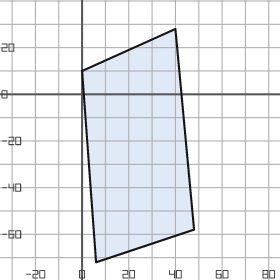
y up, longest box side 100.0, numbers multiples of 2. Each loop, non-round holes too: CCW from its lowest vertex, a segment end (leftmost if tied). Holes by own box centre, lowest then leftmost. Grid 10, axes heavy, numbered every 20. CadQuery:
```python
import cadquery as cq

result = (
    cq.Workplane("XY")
    .moveTo(6.0, -72.0)
    .lineTo(48.0, -58.0)
    .lineTo(40.0, 28.0)
    .lineTo(0.0, 10.0)
    .close()
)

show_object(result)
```